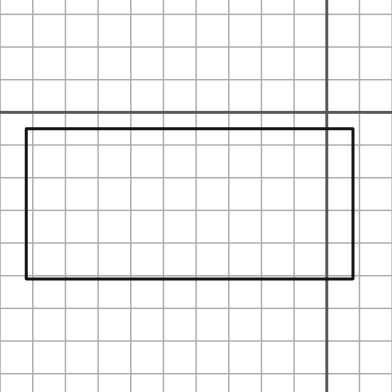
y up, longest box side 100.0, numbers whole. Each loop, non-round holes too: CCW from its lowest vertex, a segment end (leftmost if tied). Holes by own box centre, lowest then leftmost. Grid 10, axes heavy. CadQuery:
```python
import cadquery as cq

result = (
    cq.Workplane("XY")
    .moveTo(-92.0, -51.0)
    .lineTo(8.0, -51.0)
    .lineTo(8.0, -5.0)
    .lineTo(-92.0, -5.0)
    .close()
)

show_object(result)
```